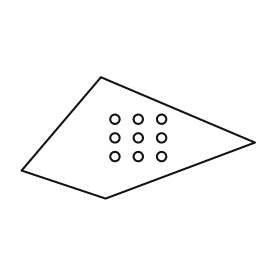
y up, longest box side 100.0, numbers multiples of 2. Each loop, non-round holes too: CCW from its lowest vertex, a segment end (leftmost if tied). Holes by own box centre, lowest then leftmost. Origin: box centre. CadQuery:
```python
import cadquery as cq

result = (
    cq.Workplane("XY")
    .moveTo(-14.0, -26.0)
    .lineTo(50.0, -2.0)
    .lineTo(-16.0, 26.0)
    .lineTo(-50.0, -14.0)
    .close()
    .moveTo(-10.0, -8.0)
    .circle(2.0)
    .moveTo(0.0, -8.0)
    .circle(2.0)
    .moveTo(10.0, -8.0)
    .circle(2.0)
    .moveTo(-10.0, 0.0)
    .circle(2.0)
    .moveTo(0.0, 0.0)
    .circle(2.0)
    .moveTo(10.0, 0.0)
    .circle(2.0)
    .moveTo(-10.0, 8.0)
    .circle(2.0)
    .moveTo(0.0, 8.0)
    .circle(2.0)
    .moveTo(10.0, 8.0)
    .circle(2.0)
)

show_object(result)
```